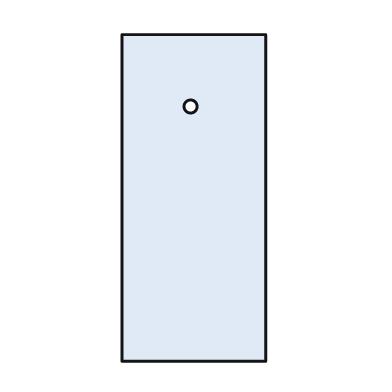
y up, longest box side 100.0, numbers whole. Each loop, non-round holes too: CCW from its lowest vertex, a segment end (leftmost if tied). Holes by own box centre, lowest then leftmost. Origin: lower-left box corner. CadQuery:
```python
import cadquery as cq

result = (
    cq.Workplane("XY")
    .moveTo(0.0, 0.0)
    .lineTo(44.0, 0.0)
    .lineTo(44.0, 100.0)
    .lineTo(0.0, 100.0)
    .close()
    .moveTo(21.0, 78.0)
    .circle(2.0)
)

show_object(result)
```